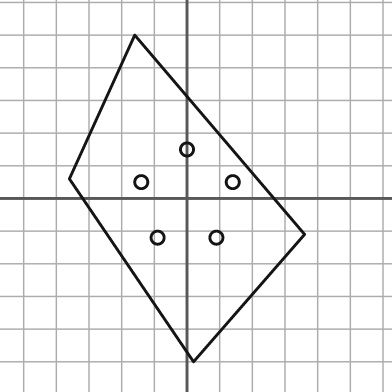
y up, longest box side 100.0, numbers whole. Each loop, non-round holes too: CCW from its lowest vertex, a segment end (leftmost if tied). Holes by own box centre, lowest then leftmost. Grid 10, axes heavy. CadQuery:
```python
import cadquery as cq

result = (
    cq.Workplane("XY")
    .moveTo(2.0, -50.0)
    .lineTo(36.0, -11.0)
    .lineTo(-16.0, 50.0)
    .lineTo(-36.0, 6.0)
    .close()
    .moveTo(-9.0, -12.0)
    .circle(2.0)
    .moveTo(9.0, -12.0)
    .circle(2.0)
    .moveTo(-14.0, 5.0)
    .circle(2.0)
    .moveTo(14.0, 5.0)
    .circle(2.0)
    .moveTo(0.0, 15.0)
    .circle(2.0)
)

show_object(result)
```